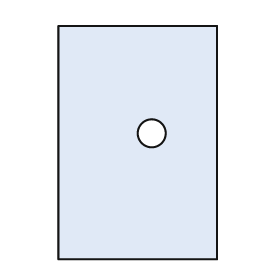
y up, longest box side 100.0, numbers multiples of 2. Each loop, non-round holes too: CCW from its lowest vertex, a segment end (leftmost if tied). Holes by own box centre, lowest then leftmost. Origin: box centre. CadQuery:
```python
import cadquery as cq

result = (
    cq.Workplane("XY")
    .moveTo(-34.0, -50.0)
    .lineTo(34.0, -50.0)
    .lineTo(34.0, 50.0)
    .lineTo(-34.0, 50.0)
    .close()
    .moveTo(6.0, 4.0)
    .circle(6.0)
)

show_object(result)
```